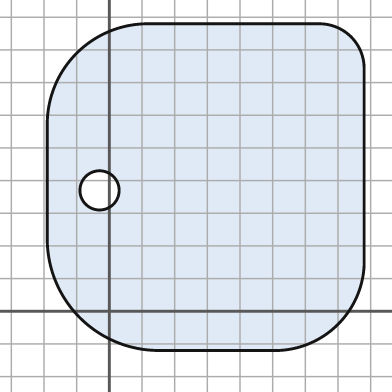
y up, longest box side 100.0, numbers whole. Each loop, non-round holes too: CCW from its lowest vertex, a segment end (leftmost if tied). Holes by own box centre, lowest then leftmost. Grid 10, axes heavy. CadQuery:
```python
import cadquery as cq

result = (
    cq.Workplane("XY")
    .moveTo(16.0, -12.0)
    .lineTo(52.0, -12.0)
    .threePointArc((70.0, -4.0), (78.0, 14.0))
    .lineTo(78.0, 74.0)
    .threePointArc((74.0, 84.0), (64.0, 88.0))
    .lineTo(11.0, 88.0)
    .threePointArc((-10.0, 79.0), (-19.0, 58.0))
    .lineTo(-19.0, 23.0)
    .threePointArc((-9.0, -2.0), (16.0, -12.0))
    .close()
    .moveTo(-3.0, 37.0)
    .circle(6.0)
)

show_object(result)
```